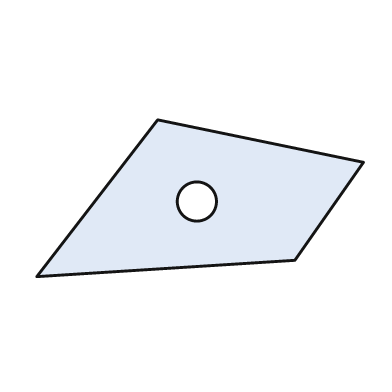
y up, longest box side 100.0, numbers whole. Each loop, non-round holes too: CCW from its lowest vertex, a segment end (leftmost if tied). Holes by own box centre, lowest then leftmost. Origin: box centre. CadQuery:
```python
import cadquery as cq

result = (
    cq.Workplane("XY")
    .moveTo(-50.0, -24.0)
    .lineTo(29.0, -19.0)
    .lineTo(50.0, 11.0)
    .lineTo(-13.0, 24.0)
    .close()
    .moveTo(-1.0, -1.0)
    .circle(6.0)
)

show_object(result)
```